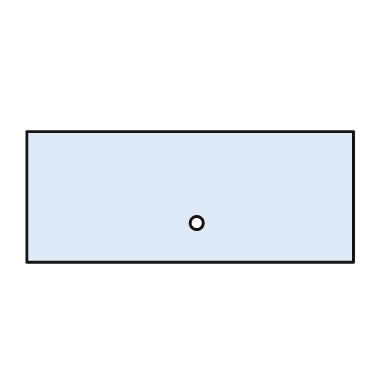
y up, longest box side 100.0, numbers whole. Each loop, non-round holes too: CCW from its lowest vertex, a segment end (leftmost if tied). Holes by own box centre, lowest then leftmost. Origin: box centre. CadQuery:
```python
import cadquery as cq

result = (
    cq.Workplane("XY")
    .moveTo(-50.0, -20.0)
    .lineTo(50.0, -20.0)
    .lineTo(50.0, 20.0)
    .lineTo(-50.0, 20.0)
    .close()
    .moveTo(2.0, -8.0)
    .circle(2.0)
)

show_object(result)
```